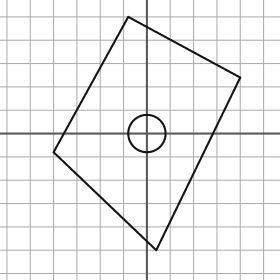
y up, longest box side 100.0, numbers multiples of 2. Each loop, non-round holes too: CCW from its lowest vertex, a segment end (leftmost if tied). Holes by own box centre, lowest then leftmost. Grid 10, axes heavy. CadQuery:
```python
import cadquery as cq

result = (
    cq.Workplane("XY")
    .moveTo(4.0, -50.0)
    .lineTo(40.0, 24.0)
    .lineTo(-8.0, 50.0)
    .lineTo(-40.0, -8.0)
    .close()
    .moveTo(0.0, 0.0)
    .circle(8.0)
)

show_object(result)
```